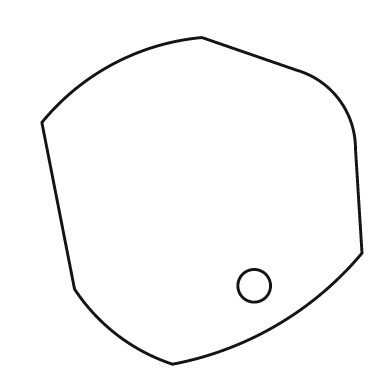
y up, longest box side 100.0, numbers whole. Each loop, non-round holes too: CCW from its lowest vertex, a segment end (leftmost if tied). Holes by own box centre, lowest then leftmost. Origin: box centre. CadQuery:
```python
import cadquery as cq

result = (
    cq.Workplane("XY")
    .moveTo(-9.0, -50.0)
    .threePointArc((23.0, -38.0), (49.0, -16.0))
    .lineTo(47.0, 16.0)
    .threePointArc((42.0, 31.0), (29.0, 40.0))
    .lineTo(0.0, 50.0)
    .threePointArc((-27.0, 42.0), (-49.0, 24.0))
    .lineTo(-39.0, -27.0)
    .threePointArc((-26.0, -41.0), (-9.0, -50.0))
    .close()
    .moveTo(16.0, -26.0)
    .circle(5.0)
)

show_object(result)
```